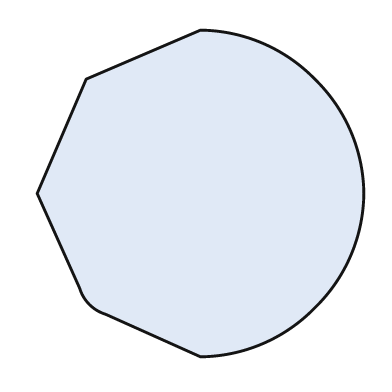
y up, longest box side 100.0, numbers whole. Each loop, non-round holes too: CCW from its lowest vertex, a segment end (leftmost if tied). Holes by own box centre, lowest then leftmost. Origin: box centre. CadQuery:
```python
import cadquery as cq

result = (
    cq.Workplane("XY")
    .moveTo(0.0, -50.0)
    .threePointArc((19.0, -46.0), (35.0, -35.0))
    .threePointArc((46.0, -19.0), (50.0, 0.0))
    .threePointArc((46.0, 19.0), (35.0, 35.0))
    .threePointArc((19.0, 46.0), (0.0, 50.0))
    .lineTo(-35.0, 35.0)
    .lineTo(-50.0, 0.0)
    .lineTo(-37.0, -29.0)
    .threePointArc((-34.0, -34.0), (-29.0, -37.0))
    .close()
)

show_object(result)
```